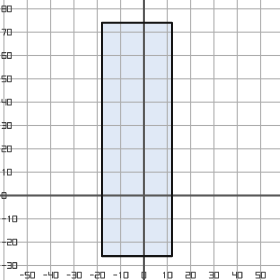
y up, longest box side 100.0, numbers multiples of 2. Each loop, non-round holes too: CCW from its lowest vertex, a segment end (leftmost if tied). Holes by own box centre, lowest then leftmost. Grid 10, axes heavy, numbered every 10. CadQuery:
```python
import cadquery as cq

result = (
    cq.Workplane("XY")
    .moveTo(-18.0, -26.0)
    .lineTo(12.0, -26.0)
    .lineTo(12.0, 74.0)
    .lineTo(-18.0, 74.0)
    .close()
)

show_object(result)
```